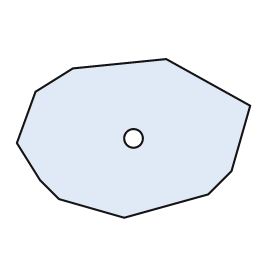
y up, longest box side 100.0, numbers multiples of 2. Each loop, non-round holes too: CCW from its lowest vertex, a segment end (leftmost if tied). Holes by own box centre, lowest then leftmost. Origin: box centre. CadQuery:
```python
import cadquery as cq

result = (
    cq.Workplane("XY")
    .moveTo(-4.0, -34.0)
    .lineTo(32.0, -24.0)
    .lineTo(42.0, -14.0)
    .lineTo(50.0, 14.0)
    .lineTo(14.0, 34.0)
    .lineTo(-26.0, 30.0)
    .lineTo(-42.0, 20.0)
    .lineTo(-50.0, -2.0)
    .lineTo(-40.0, -18.0)
    .lineTo(-32.0, -26.0)
    .close()
    .moveTo(0.0, 0.0)
    .circle(4.0)
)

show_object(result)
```